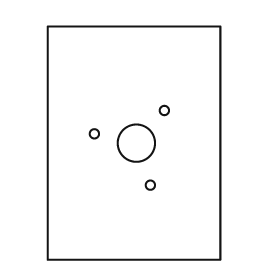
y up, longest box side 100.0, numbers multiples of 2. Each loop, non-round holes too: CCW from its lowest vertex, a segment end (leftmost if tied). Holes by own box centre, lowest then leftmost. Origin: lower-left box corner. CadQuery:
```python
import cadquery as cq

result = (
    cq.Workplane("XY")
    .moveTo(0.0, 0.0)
    .lineTo(74.0, 0.0)
    .lineTo(74.0, 100.0)
    .lineTo(0.0, 100.0)
    .close()
    .moveTo(44.0, 32.0)
    .circle(2.0)
    .moveTo(38.0, 50.0)
    .circle(8.0)
    .moveTo(20.0, 54.0)
    .circle(2.0)
    .moveTo(50.0, 64.0)
    .circle(2.0)
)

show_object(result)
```